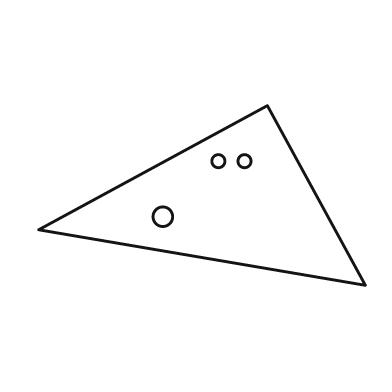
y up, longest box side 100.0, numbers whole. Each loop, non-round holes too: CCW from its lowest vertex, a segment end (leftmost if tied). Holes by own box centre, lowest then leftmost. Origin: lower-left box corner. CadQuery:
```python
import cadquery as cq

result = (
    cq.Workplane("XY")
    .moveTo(100.0, 0.0)
    .lineTo(70.0, 55.0)
    .lineTo(0.0, 17.0)
    .close()
    .moveTo(38.0, 21.0)
    .circle(3.0)
    .moveTo(55.0, 38.0)
    .circle(2.0)
    .moveTo(63.0, 38.0)
    .circle(2.0)
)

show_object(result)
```